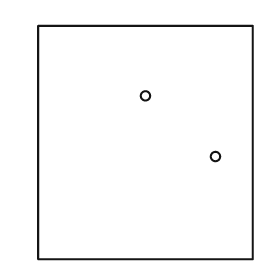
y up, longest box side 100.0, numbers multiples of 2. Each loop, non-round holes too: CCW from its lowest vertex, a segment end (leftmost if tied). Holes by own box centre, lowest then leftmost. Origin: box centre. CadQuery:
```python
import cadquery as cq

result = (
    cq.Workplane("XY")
    .moveTo(-46.0, -50.0)
    .lineTo(46.0, -50.0)
    .lineTo(46.0, 50.0)
    .lineTo(-46.0, 50.0)
    .close()
    .moveTo(30.0, -6.0)
    .circle(2.0)
    .moveTo(0.0, 20.0)
    .circle(2.0)
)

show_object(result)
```